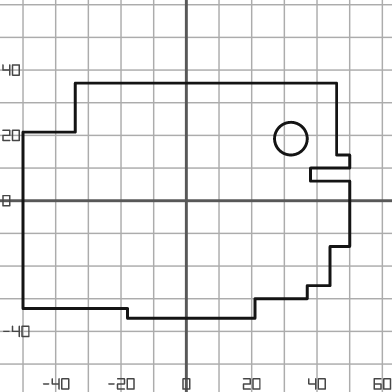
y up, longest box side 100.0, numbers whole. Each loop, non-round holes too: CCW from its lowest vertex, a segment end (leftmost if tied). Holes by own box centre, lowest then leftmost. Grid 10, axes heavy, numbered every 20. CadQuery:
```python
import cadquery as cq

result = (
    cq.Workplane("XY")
    .moveTo(-18.0, -36.0)
    .lineTo(21.0, -36.0)
    .lineTo(21.0, -30.0)
    .lineTo(37.0, -30.0)
    .lineTo(37.0, -26.0)
    .lineTo(44.0, -26.0)
    .lineTo(44.0, -14.0)
    .lineTo(50.0, -14.0)
    .lineTo(50.0, 6.0)
    .lineTo(38.0, 6.0)
    .lineTo(38.0, 10.0)
    .lineTo(50.0, 10.0)
    .lineTo(50.0, 14.0)
    .lineTo(46.0, 14.0)
    .lineTo(46.0, 36.0)
    .lineTo(-34.0, 36.0)
    .lineTo(-34.0, 21.0)
    .lineTo(-50.0, 21.0)
    .lineTo(-50.0, -33.0)
    .lineTo(-18.0, -33.0)
    .close()
    .moveTo(32.0, 19.0)
    .circle(5.0)
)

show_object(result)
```